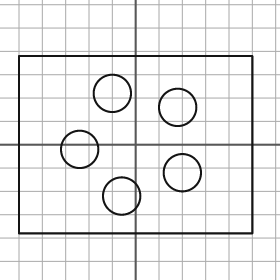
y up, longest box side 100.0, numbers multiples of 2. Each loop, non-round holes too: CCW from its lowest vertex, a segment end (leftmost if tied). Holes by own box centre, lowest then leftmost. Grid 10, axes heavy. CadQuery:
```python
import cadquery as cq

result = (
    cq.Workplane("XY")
    .moveTo(-50.0, -38.0)
    .lineTo(50.0, -38.0)
    .lineTo(50.0, 38.0)
    .lineTo(-50.0, 38.0)
    .close()
    .moveTo(-6.0, -22.0)
    .circle(8.0)
    .moveTo(20.0, -12.0)
    .circle(8.0)
    .moveTo(-24.0, -2.0)
    .circle(8.0)
    .moveTo(18.0, 16.0)
    .circle(8.0)
    .moveTo(-10.0, 22.0)
    .circle(8.0)
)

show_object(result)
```